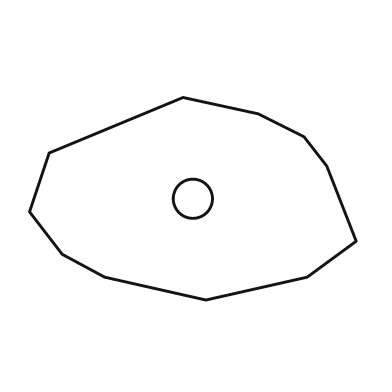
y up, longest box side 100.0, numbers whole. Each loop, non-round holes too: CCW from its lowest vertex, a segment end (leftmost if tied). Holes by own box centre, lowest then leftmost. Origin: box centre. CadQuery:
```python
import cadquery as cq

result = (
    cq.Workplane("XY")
    .moveTo(4.0, -31.0)
    .lineTo(35.0, -24.0)
    .lineTo(50.0, -13.0)
    .lineTo(41.0, 10.0)
    .lineTo(34.0, 19.0)
    .lineTo(20.0, 26.0)
    .lineTo(-3.0, 31.0)
    .lineTo(-44.0, 14.0)
    .lineTo(-50.0, -4.0)
    .lineTo(-40.0, -17.0)
    .lineTo(-27.0, -24.0)
    .close()
    .moveTo(0.0, 0.0)
    .circle(6.0)
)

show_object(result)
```